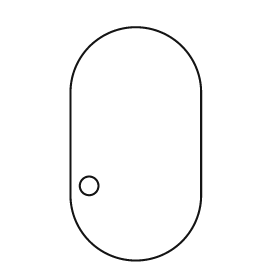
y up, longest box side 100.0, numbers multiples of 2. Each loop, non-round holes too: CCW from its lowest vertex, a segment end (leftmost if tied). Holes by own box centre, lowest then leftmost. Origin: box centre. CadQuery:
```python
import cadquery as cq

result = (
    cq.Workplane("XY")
    .moveTo(-28.0, -22.0)
    .threePointArc((0.0, -50.0), (28.0, -22.0))
    .lineTo(28.0, 22.0)
    .threePointArc((0.0, 50.0), (-28.0, 22.0))
    .close()
    .moveTo(-20.0, -18.0)
    .circle(4.0)
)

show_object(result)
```